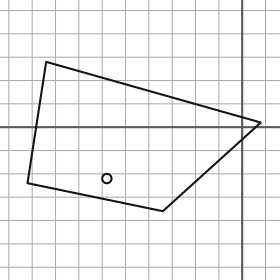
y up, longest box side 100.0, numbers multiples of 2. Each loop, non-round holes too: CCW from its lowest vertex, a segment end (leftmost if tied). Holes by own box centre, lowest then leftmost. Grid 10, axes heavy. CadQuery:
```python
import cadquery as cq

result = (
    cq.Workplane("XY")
    .moveTo(-34.0, -36.0)
    .lineTo(8.0, 2.0)
    .lineTo(-84.0, 28.0)
    .lineTo(-92.0, -24.0)
    .close()
    .moveTo(-58.0, -22.0)
    .circle(2.0)
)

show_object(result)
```